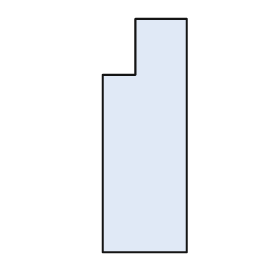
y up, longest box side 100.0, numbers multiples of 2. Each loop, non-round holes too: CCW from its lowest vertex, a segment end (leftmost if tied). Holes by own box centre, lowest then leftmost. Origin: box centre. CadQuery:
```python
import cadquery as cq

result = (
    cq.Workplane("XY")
    .moveTo(-18.0, -50.0)
    .lineTo(18.0, -50.0)
    .lineTo(18.0, 50.0)
    .lineTo(-4.0, 50.0)
    .lineTo(-4.0, 26.0)
    .lineTo(-18.0, 26.0)
    .close()
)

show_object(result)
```